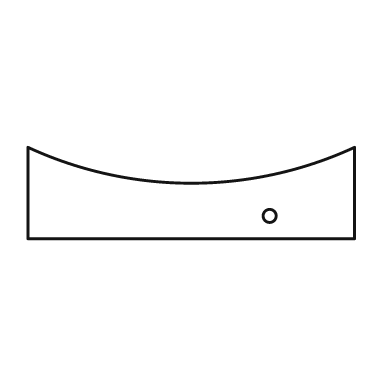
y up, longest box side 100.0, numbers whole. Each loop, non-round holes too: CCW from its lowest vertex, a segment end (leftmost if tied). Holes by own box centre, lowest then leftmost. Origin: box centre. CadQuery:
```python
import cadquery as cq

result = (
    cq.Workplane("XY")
    .moveTo(-50.0, -14.0)
    .lineTo(50.0, -14.0)
    .lineTo(50.0, 14.0)
    .threePointArc((0.0, 3.0), (-50.0, 14.0))
    .close()
    .moveTo(24.0, -7.0)
    .circle(2.0)
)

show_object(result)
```